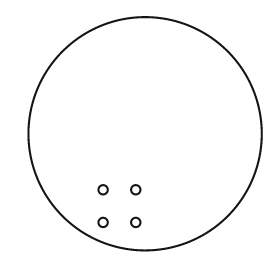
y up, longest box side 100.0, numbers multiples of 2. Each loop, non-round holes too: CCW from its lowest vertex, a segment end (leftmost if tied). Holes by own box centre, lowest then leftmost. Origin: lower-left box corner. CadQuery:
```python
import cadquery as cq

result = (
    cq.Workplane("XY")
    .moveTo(50.0, 50.0)
    .circle(50.0)
    .moveTo(32.0, 12.0)
    .circle(2.0)
    .moveTo(46.0, 12.0)
    .circle(2.0)
    .moveTo(32.0, 26.0)
    .circle(2.0)
    .moveTo(46.0, 26.0)
    .circle(2.0)
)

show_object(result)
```